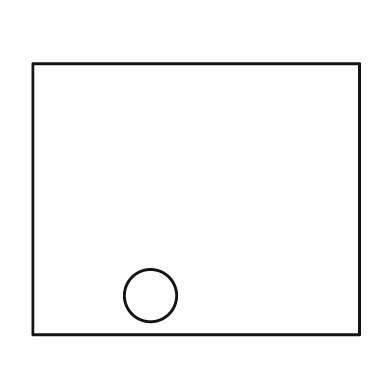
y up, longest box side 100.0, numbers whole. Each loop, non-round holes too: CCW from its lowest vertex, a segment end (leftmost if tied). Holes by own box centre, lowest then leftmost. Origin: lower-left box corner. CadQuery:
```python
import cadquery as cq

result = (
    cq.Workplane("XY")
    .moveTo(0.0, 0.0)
    .lineTo(100.0, 0.0)
    .lineTo(100.0, 83.0)
    .lineTo(0.0, 83.0)
    .close()
    .moveTo(36.0, 12.0)
    .circle(8.0)
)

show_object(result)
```